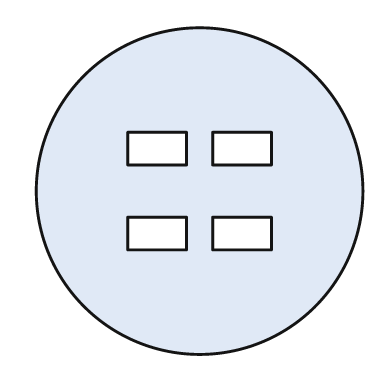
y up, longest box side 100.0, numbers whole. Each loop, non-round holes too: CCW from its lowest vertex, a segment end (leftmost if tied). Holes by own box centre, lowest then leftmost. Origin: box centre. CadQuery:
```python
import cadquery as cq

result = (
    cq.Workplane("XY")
    .moveTo(0.0, 0.0)
    .circle(50.0)
    .moveTo(-22.0, -18.0)
    .lineTo(-4.0, -18.0)
    .lineTo(-4.0, -8.0)
    .lineTo(-22.0, -8.0)
    .close()
    .moveTo(4.0, -18.0)
    .lineTo(22.0, -18.0)
    .lineTo(22.0, -8.0)
    .lineTo(4.0, -8.0)
    .close()
    .moveTo(-22.0, 8.0)
    .lineTo(-4.0, 8.0)
    .lineTo(-4.0, 18.0)
    .lineTo(-22.0, 18.0)
    .close()
    .moveTo(4.0, 8.0)
    .lineTo(22.0, 8.0)
    .lineTo(22.0, 18.0)
    .lineTo(4.0, 18.0)
    .close()
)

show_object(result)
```